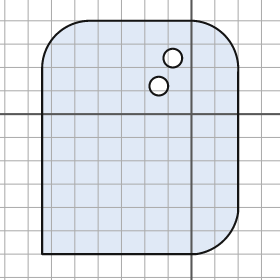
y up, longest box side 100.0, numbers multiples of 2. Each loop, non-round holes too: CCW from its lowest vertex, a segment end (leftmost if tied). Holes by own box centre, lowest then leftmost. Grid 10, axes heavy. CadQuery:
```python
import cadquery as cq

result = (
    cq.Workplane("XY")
    .moveTo(-64.0, -60.0)
    .lineTo(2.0, -60.0)
    .threePointArc((14.0, -54.0), (20.0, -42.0))
    .lineTo(20.0, 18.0)
    .threePointArc((14.0, 34.0), (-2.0, 40.0))
    .lineTo(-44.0, 40.0)
    .threePointArc((-58.0, 34.0), (-64.0, 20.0))
    .close()
    .moveTo(-14.0, 12.0)
    .circle(4.0)
    .moveTo(-8.0, 24.0)
    .circle(4.0)
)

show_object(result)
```